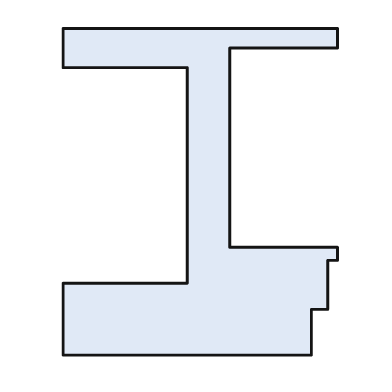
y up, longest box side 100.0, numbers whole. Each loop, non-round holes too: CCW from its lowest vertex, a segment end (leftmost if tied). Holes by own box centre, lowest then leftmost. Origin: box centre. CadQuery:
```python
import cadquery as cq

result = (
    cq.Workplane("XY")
    .moveTo(-42.0, -50.0)
    .lineTo(34.0, -50.0)
    .lineTo(34.0, -36.0)
    .lineTo(39.0, -36.0)
    .lineTo(39.0, -21.0)
    .lineTo(42.0, -21.0)
    .lineTo(42.0, -17.0)
    .lineTo(9.0, -17.0)
    .lineTo(9.0, 44.0)
    .lineTo(42.0, 44.0)
    .lineTo(42.0, 50.0)
    .lineTo(-42.0, 50.0)
    .lineTo(-42.0, 38.0)
    .lineTo(-4.0, 38.0)
    .lineTo(-4.0, -28.0)
    .lineTo(-42.0, -28.0)
    .close()
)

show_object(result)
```